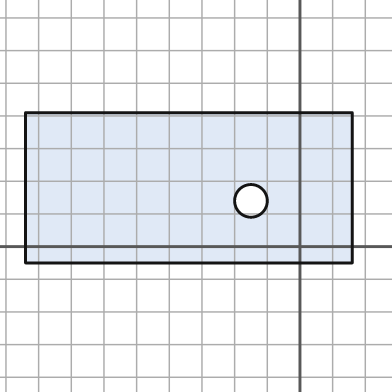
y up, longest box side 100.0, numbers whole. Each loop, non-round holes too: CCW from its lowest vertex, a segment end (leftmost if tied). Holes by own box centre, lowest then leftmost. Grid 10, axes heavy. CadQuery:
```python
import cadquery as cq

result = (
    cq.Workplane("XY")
    .moveTo(-84.0, -5.0)
    .lineTo(16.0, -5.0)
    .lineTo(16.0, 41.0)
    .lineTo(-84.0, 41.0)
    .close()
    .moveTo(-15.0, 14.0)
    .circle(5.0)
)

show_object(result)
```